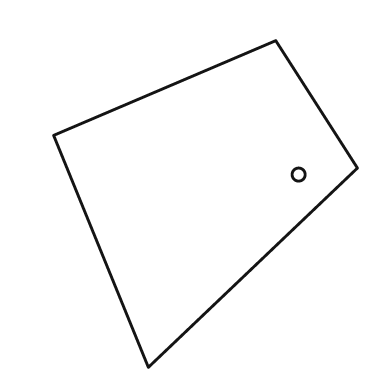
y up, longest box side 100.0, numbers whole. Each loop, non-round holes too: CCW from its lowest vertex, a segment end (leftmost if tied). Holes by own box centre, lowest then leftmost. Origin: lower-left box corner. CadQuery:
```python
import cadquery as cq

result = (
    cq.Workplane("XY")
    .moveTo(29.0, 0.0)
    .lineTo(93.0, 61.0)
    .lineTo(68.0, 100.0)
    .lineTo(0.0, 71.0)
    .close()
    .moveTo(75.0, 59.0)
    .circle(2.0)
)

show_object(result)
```